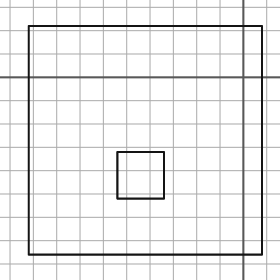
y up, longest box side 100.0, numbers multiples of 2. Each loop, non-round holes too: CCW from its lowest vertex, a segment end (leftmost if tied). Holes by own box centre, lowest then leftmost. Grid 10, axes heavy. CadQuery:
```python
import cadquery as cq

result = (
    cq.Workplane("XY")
    .moveTo(-92.0, -76.0)
    .lineTo(8.0, -76.0)
    .lineTo(8.0, 22.0)
    .lineTo(-92.0, 22.0)
    .close()
    .moveTo(-54.0, -52.0)
    .lineTo(-34.0, -52.0)
    .lineTo(-34.0, -32.0)
    .lineTo(-54.0, -32.0)
    .close()
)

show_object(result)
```